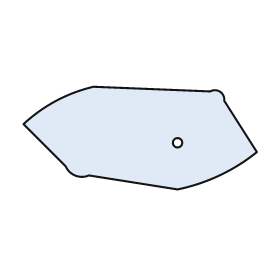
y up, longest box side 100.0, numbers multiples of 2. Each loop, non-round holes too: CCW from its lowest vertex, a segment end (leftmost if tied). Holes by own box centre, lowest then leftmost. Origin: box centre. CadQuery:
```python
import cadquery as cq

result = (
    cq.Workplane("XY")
    .moveTo(16.0, -22.0)
    .threePointArc((34.0, -16.0), (50.0, -6.0))
    .lineTo(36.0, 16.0)
    .threePointArc((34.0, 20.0), (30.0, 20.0))
    .lineTo(-20.0, 22.0)
    .threePointArc((-36.0, 16.0), (-50.0, 6.0))
    .lineTo(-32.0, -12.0)
    .threePointArc((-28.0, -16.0), (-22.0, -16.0))
    .close()
    .moveTo(16.0, -2.0)
    .circle(2.0)
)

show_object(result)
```